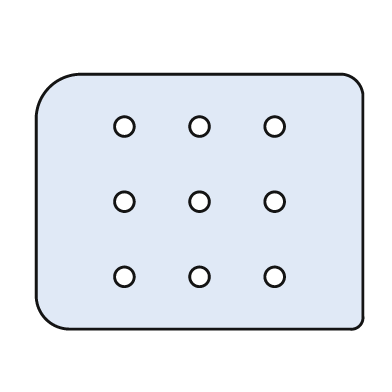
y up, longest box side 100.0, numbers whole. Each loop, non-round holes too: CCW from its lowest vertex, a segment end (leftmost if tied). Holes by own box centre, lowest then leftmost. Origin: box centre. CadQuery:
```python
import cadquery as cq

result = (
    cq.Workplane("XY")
    .moveTo(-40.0, -39.0)
    .lineTo(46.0, -39.0)
    .threePointArc((49.0, -38.0), (50.0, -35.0))
    .lineTo(50.0, 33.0)
    .threePointArc((48.0, 37.0), (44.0, 39.0))
    .lineTo(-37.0, 39.0)
    .threePointArc((-46.0, 35.0), (-50.0, 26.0))
    .lineTo(-50.0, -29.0)
    .threePointArc((-47.0, -36.0), (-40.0, -39.0))
    .close()
    .moveTo(-23.0, -23.0)
    .circle(3.0)
    .moveTo(0.0, -23.0)
    .circle(3.0)
    .moveTo(23.0, -23.0)
    .circle(3.0)
    .moveTo(-23.0, 0.0)
    .circle(3.0)
    .moveTo(0.0, 0.0)
    .circle(3.0)
    .moveTo(23.0, 0.0)
    .circle(3.0)
    .moveTo(-23.0, 23.0)
    .circle(3.0)
    .moveTo(0.0, 23.0)
    .circle(3.0)
    .moveTo(23.0, 23.0)
    .circle(3.0)
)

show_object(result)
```